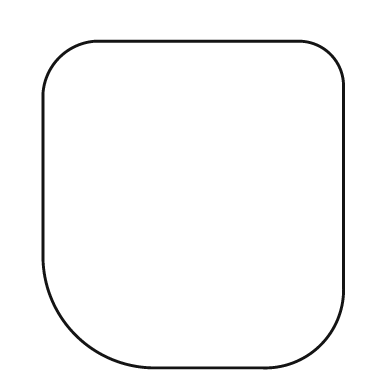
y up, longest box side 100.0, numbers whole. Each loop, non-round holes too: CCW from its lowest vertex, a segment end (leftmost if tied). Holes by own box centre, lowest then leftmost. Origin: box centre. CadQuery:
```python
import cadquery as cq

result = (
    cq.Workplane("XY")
    .moveTo(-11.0, -50.0)
    .lineTo(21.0, -50.0)
    .threePointArc((39.0, -43.0), (46.0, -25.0))
    .lineTo(46.0, 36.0)
    .threePointArc((42.0, 46.0), (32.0, 50.0))
    .lineTo(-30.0, 50.0)
    .threePointArc((-41.0, 45.0), (-46.0, 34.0))
    .lineTo(-46.0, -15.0)
    .threePointArc((-36.0, -40.0), (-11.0, -50.0))
    .close()
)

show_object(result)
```